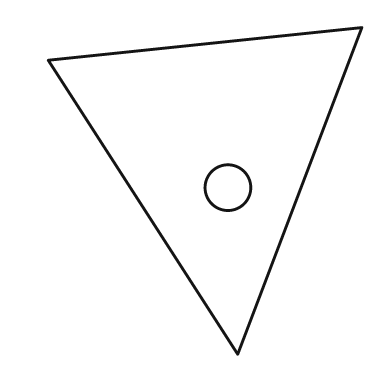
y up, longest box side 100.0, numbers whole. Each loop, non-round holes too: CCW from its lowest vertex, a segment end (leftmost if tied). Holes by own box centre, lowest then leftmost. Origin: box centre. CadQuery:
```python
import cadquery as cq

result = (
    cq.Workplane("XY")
    .moveTo(10.0, -50.0)
    .lineTo(48.0, 50.0)
    .lineTo(-48.0, 40.0)
    .close()
    .moveTo(7.0, 1.0)
    .circle(7.0)
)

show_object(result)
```